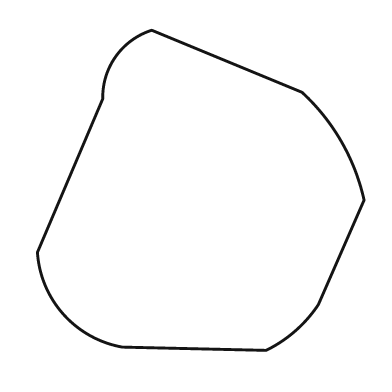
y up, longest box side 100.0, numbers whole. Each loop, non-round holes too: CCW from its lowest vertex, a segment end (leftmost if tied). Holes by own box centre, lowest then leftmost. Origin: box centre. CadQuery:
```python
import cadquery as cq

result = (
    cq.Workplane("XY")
    .moveTo(20.0, -49.0)
    .threePointArc((29.0, -43.0), (36.0, -35.0))
    .lineTo(50.0, -3.0)
    .threePointArc((43.0, 15.0), (31.0, 30.0))
    .lineTo(-15.0, 49.0)
    .threePointArc((-26.0, 41.0), (-30.0, 28.0))
    .lineTo(-50.0, -19.0)
    .threePointArc((-42.0, -38.0), (-24.0, -48.0))
    .close()
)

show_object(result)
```